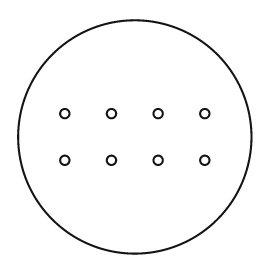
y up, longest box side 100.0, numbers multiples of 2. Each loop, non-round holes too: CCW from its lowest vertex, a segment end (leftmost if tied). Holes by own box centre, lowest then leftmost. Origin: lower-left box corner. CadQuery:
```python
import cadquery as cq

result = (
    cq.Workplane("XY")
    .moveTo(50.0, 50.0)
    .circle(50.0)
    .moveTo(20.0, 40.0)
    .circle(2.0)
    .moveTo(40.0, 40.0)
    .circle(2.0)
    .moveTo(60.0, 40.0)
    .circle(2.0)
    .moveTo(80.0, 40.0)
    .circle(2.0)
    .moveTo(20.0, 60.0)
    .circle(2.0)
    .moveTo(40.0, 60.0)
    .circle(2.0)
    .moveTo(60.0, 60.0)
    .circle(2.0)
    .moveTo(80.0, 60.0)
    .circle(2.0)
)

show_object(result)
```